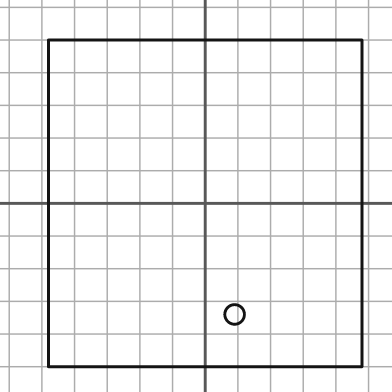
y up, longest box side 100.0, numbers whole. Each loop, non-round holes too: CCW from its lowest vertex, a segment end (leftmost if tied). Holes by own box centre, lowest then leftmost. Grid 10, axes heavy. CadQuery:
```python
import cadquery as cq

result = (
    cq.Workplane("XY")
    .moveTo(-48.0, -50.0)
    .lineTo(48.0, -50.0)
    .lineTo(48.0, 50.0)
    .lineTo(-48.0, 50.0)
    .close()
    .moveTo(9.0, -34.0)
    .circle(3.0)
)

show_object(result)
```